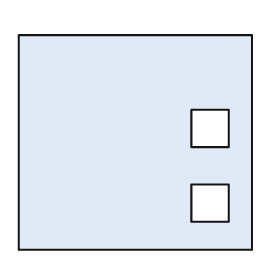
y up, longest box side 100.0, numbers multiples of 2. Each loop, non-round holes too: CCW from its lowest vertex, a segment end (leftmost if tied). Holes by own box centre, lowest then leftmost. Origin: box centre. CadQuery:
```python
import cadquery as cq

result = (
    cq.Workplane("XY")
    .moveTo(-50.0, -46.0)
    .lineTo(50.0, -46.0)
    .lineTo(50.0, 46.0)
    .lineTo(-50.0, 46.0)
    .close()
    .moveTo(24.0, -34.0)
    .lineTo(40.0, -34.0)
    .lineTo(40.0, -18.0)
    .lineTo(24.0, -18.0)
    .close()
    .moveTo(24.0, -2.0)
    .lineTo(40.0, -2.0)
    .lineTo(40.0, 14.0)
    .lineTo(24.0, 14.0)
    .close()
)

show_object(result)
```